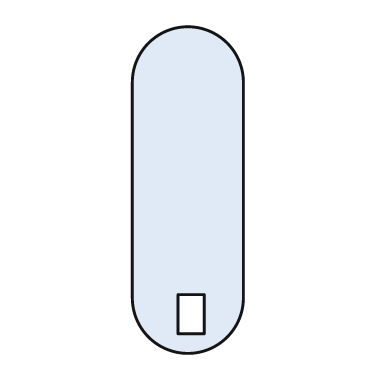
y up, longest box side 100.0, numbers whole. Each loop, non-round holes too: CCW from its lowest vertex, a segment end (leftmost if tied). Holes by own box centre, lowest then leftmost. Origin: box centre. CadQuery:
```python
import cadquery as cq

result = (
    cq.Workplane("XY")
    .moveTo(-17.0, -33.0)
    .threePointArc((0.0, -50.0), (17.0, -33.0))
    .lineTo(17.0, 33.0)
    .threePointArc((0.0, 50.0), (-17.0, 33.0))
    .close()
    .moveTo(-3.0, -44.0)
    .lineTo(5.0, -44.0)
    .lineTo(5.0, -32.0)
    .lineTo(-3.0, -32.0)
    .close()
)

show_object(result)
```